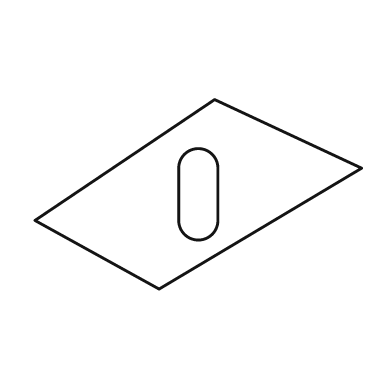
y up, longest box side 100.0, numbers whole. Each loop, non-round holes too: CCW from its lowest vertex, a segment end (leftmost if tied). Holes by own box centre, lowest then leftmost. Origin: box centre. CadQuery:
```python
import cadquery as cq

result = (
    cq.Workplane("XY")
    .moveTo(-12.0, -29.0)
    .lineTo(50.0, 8.0)
    .lineTo(5.0, 29.0)
    .lineTo(-50.0, -8.0)
    .close()
    .moveTo(-6.0, -8.0)
    .threePointArc((0.0, -14.0), (6.0, -8.0))
    .lineTo(6.0, 8.0)
    .threePointArc((0.0, 14.0), (-6.0, 8.0))
    .close()
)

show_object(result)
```